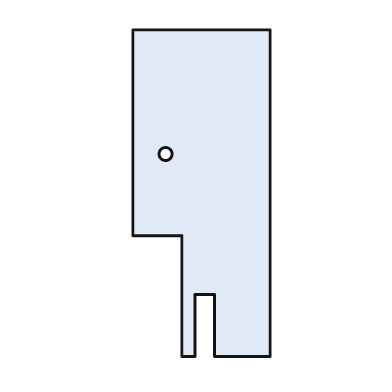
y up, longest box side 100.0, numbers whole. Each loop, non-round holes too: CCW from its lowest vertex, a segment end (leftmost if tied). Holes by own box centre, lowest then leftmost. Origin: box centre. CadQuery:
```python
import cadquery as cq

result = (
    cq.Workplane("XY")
    .moveTo(-6.0, -50.0)
    .lineTo(-2.0, -50.0)
    .lineTo(-2.0, -31.0)
    .lineTo(4.0, -31.0)
    .lineTo(4.0, -50.0)
    .lineTo(21.0, -50.0)
    .lineTo(21.0, 50.0)
    .lineTo(-21.0, 50.0)
    .lineTo(-21.0, -13.0)
    .lineTo(-6.0, -13.0)
    .close()
    .moveTo(-11.0, 12.0)
    .circle(2.0)
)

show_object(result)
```